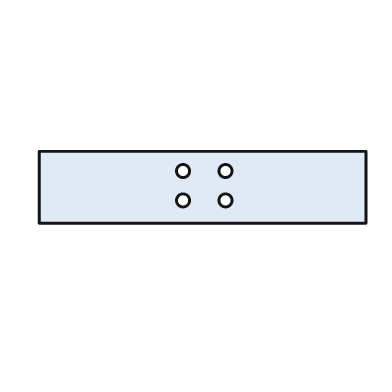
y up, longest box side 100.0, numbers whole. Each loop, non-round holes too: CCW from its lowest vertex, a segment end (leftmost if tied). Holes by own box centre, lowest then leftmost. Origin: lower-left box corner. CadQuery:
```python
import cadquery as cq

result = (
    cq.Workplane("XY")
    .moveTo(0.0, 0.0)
    .lineTo(100.0, 0.0)
    .lineTo(100.0, 22.0)
    .lineTo(0.0, 22.0)
    .close()
    .moveTo(44.0, 7.0)
    .circle(2.0)
    .moveTo(57.0, 7.0)
    .circle(2.0)
    .moveTo(44.0, 16.0)
    .circle(2.0)
    .moveTo(57.0, 16.0)
    .circle(2.0)
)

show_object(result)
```